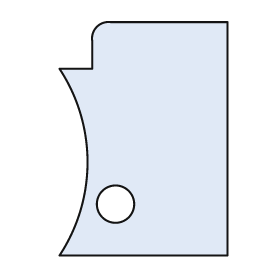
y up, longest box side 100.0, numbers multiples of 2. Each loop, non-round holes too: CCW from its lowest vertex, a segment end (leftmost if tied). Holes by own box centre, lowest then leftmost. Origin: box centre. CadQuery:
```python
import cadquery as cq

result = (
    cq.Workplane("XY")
    .moveTo(-36.0, -50.0)
    .lineTo(36.0, -50.0)
    .lineTo(36.0, 50.0)
    .lineTo(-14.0, 50.0)
    .threePointArc((-20.0, 48.0), (-22.0, 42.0))
    .lineTo(-22.0, 30.0)
    .lineTo(-36.0, 30.0)
    .threePointArc((-24.0, -10.0), (-36.0, -50.0))
    .close()
    .moveTo(-12.0, -28.0)
    .circle(8.0)
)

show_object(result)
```